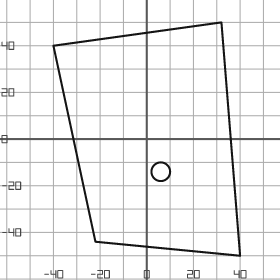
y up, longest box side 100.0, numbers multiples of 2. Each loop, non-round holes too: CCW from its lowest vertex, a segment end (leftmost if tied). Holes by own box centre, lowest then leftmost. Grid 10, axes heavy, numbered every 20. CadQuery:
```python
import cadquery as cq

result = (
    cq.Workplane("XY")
    .moveTo(40.0, -50.0)
    .lineTo(32.0, 50.0)
    .lineTo(-40.0, 40.0)
    .lineTo(-22.0, -44.0)
    .close()
    .moveTo(6.0, -14.0)
    .circle(4.0)
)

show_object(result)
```